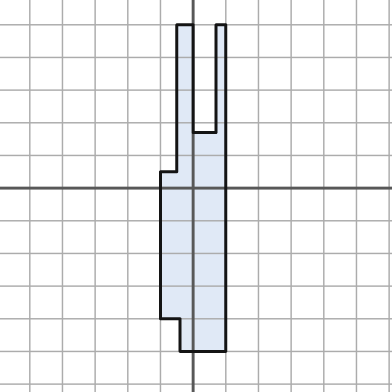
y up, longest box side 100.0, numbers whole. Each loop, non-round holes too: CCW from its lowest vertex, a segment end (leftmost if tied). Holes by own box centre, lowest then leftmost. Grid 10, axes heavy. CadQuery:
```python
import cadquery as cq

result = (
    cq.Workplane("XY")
    .moveTo(-4.0, -50.0)
    .lineTo(10.0, -50.0)
    .lineTo(10.0, 50.0)
    .lineTo(7.0, 50.0)
    .lineTo(7.0, 17.0)
    .lineTo(0.0, 17.0)
    .lineTo(0.0, 50.0)
    .lineTo(-5.0, 50.0)
    .lineTo(-5.0, 5.0)
    .lineTo(-10.0, 5.0)
    .lineTo(-10.0, -40.0)
    .lineTo(-4.0, -40.0)
    .close()
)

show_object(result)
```